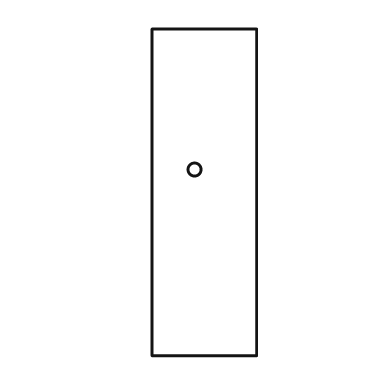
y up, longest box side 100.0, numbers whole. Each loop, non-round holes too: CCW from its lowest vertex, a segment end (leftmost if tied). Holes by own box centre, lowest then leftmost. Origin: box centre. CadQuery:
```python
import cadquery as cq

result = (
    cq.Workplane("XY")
    .moveTo(-16.0, -50.0)
    .lineTo(16.0, -50.0)
    .lineTo(16.0, 50.0)
    .lineTo(-16.0, 50.0)
    .close()
    .moveTo(-3.0, 7.0)
    .circle(2.0)
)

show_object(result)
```